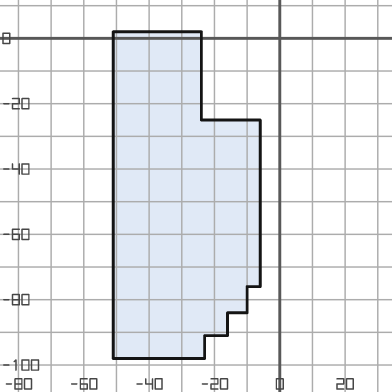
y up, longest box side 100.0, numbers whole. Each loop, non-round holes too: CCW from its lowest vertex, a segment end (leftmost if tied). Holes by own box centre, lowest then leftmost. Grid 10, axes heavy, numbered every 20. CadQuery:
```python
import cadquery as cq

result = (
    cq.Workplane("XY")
    .moveTo(-51.0, -98.0)
    .lineTo(-23.0, -98.0)
    .lineTo(-23.0, -91.0)
    .lineTo(-16.0, -91.0)
    .lineTo(-16.0, -84.0)
    .lineTo(-10.0, -84.0)
    .lineTo(-10.0, -76.0)
    .lineTo(-6.0, -76.0)
    .lineTo(-6.0, -25.0)
    .lineTo(-24.0, -25.0)
    .lineTo(-24.0, 2.0)
    .lineTo(-51.0, 2.0)
    .close()
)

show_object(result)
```